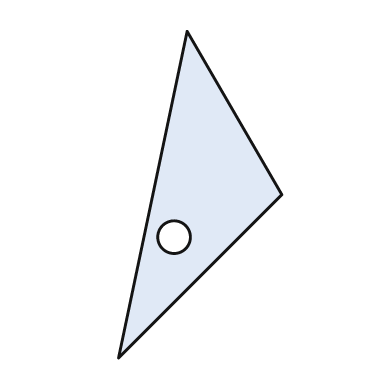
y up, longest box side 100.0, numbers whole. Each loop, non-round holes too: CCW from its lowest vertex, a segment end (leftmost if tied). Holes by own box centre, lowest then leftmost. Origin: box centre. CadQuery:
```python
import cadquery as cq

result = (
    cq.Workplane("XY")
    .moveTo(-25.0, -50.0)
    .lineTo(25.0, 0.0)
    .lineTo(-4.0, 50.0)
    .close()
    .moveTo(-8.0, -13.0)
    .circle(5.0)
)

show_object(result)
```